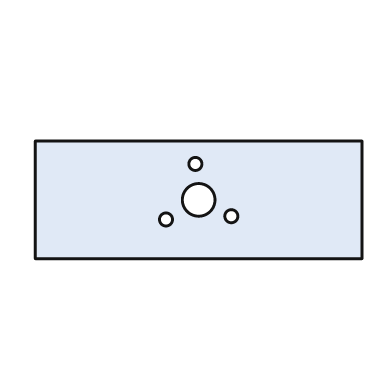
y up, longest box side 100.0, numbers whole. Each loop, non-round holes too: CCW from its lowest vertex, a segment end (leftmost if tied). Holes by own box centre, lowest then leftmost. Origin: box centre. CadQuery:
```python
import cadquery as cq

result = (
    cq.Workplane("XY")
    .moveTo(-50.0, -18.0)
    .lineTo(50.0, -18.0)
    .lineTo(50.0, 18.0)
    .lineTo(-50.0, 18.0)
    .close()
    .moveTo(-10.0, -6.0)
    .circle(2.0)
    .moveTo(10.0, -5.0)
    .circle(2.0)
    .moveTo(0.0, 0.0)
    .circle(5.0)
    .moveTo(-1.0, 11.0)
    .circle(2.0)
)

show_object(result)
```